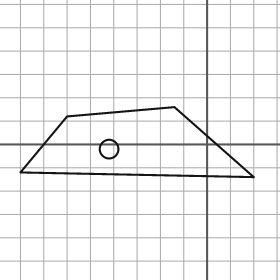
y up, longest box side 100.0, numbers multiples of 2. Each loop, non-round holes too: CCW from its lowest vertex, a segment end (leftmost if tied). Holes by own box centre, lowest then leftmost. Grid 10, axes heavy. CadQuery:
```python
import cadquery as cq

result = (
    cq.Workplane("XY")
    .moveTo(20.0, -14.0)
    .lineTo(-14.0, 16.0)
    .lineTo(-60.0, 12.0)
    .lineTo(-80.0, -12.0)
    .close()
    .moveTo(-42.0, -2.0)
    .circle(4.0)
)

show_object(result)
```